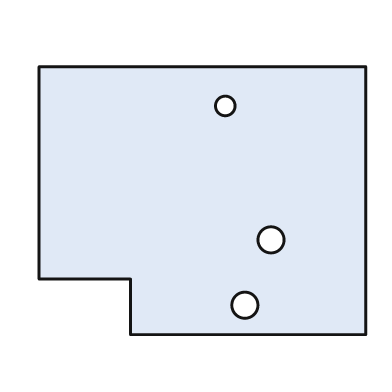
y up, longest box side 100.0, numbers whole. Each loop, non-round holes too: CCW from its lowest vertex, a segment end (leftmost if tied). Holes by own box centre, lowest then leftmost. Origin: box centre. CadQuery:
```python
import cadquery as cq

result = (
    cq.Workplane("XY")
    .moveTo(-22.0, -41.0)
    .lineTo(50.0, -41.0)
    .lineTo(50.0, 41.0)
    .lineTo(-50.0, 41.0)
    .lineTo(-50.0, -24.0)
    .lineTo(-22.0, -24.0)
    .close()
    .moveTo(13.0, -32.0)
    .circle(4.0)
    .moveTo(21.0, -12.0)
    .circle(4.0)
    .moveTo(7.0, 29.0)
    .circle(3.0)
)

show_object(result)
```